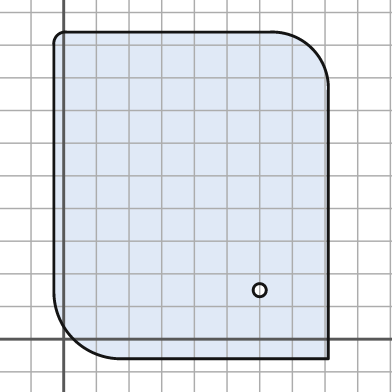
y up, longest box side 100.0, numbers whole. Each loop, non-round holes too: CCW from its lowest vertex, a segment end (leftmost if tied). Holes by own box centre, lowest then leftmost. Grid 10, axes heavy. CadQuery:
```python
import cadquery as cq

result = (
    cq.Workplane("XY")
    .moveTo(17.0, -6.0)
    .lineTo(81.0, -6.0)
    .lineTo(81.0, 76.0)
    .threePointArc((76.0, 89.0), (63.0, 94.0))
    .lineTo(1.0, 94.0)
    .threePointArc((-2.0, 93.0), (-3.0, 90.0))
    .lineTo(-3.0, 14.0)
    .threePointArc((3.0, 0.0), (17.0, -6.0))
    .close()
    .moveTo(60.0, 15.0)
    .circle(2.0)
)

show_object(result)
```